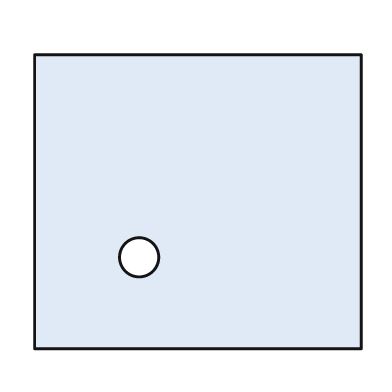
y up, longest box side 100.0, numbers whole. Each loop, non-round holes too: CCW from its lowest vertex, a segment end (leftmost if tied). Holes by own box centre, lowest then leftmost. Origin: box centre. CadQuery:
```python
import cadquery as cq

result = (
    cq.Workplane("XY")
    .moveTo(-50.0, -45.0)
    .lineTo(50.0, -45.0)
    .lineTo(50.0, 45.0)
    .lineTo(-50.0, 45.0)
    .close()
    .moveTo(-18.0, -17.0)
    .circle(6.0)
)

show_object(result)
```